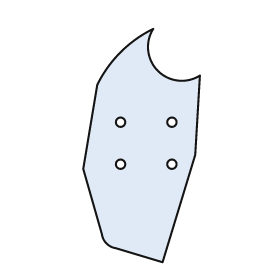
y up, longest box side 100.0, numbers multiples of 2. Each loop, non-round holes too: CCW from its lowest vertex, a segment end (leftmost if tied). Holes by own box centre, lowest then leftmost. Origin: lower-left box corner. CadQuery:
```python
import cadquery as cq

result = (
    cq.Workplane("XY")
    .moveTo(34.0, 0.0)
    .lineTo(48.0, 46.0)
    .lineTo(50.0, 80.0)
    .threePointArc((32.0, 82.0), (30.0, 100.0))
    .threePointArc((16.0, 90.0), (6.0, 76.0))
    .lineTo(0.0, 40.0)
    .lineTo(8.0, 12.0)
    .threePointArc((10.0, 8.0), (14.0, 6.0))
    .close()
    .moveTo(16.0, 42.0)
    .circle(2.0)
    .moveTo(38.0, 42.0)
    .circle(2.0)
    .moveTo(16.0, 60.0)
    .circle(2.0)
    .moveTo(38.0, 60.0)
    .circle(2.0)
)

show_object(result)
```